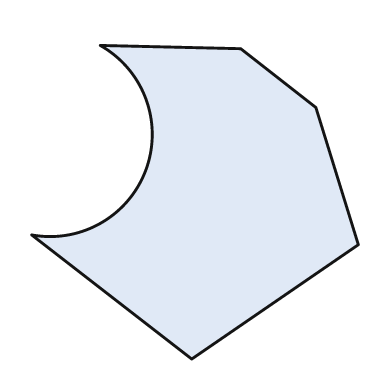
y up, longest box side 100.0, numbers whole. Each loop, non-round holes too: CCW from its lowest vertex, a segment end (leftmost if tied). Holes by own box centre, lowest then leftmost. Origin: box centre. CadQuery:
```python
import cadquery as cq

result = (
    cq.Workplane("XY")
    .moveTo(-1.0, -48.0)
    .lineTo(50.0, -13.0)
    .lineTo(37.0, 29.0)
    .lineTo(14.0, 47.0)
    .lineTo(-29.0, 48.0)
    .threePointArc((-15.0, 10.0), (-50.0, -10.0))
    .close()
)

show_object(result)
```